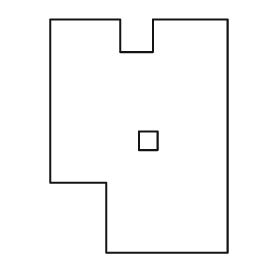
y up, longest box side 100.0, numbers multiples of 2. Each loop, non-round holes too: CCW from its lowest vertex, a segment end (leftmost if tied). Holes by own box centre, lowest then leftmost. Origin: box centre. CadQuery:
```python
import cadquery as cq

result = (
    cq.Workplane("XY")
    .moveTo(-14.0, -50.0)
    .lineTo(38.0, -50.0)
    .lineTo(38.0, 50.0)
    .lineTo(6.0, 50.0)
    .lineTo(6.0, 36.0)
    .lineTo(-8.0, 36.0)
    .lineTo(-8.0, 50.0)
    .lineTo(-38.0, 50.0)
    .lineTo(-38.0, -20.0)
    .lineTo(-14.0, -20.0)
    .close()
    .moveTo(0.0, -6.0)
    .lineTo(8.0, -6.0)
    .lineTo(8.0, 2.0)
    .lineTo(0.0, 2.0)
    .close()
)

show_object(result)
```